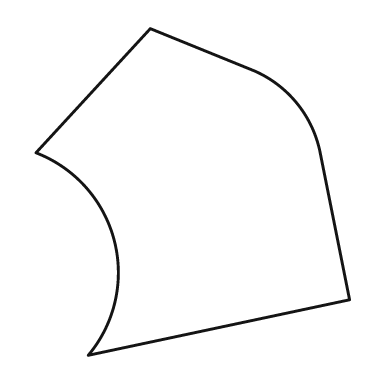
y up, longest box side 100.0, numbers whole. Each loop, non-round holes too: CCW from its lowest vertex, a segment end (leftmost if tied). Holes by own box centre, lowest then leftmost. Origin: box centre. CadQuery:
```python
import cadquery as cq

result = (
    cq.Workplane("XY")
    .moveTo(-32.0, -50.0)
    .lineTo(48.0, -33.0)
    .lineTo(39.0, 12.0)
    .threePointArc((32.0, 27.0), (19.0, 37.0))
    .lineTo(-13.0, 50.0)
    .lineTo(-48.0, 12.0)
    .threePointArc((-24.0, -15.0), (-32.0, -50.0))
    .close()
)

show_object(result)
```